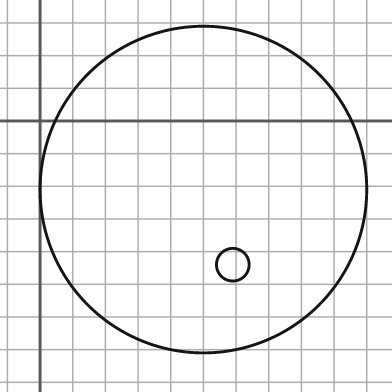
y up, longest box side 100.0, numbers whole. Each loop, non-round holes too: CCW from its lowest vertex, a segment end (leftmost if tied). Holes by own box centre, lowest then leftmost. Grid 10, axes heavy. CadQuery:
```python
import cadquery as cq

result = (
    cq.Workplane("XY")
    .moveTo(50.0, -21.0)
    .circle(50.0)
    .moveTo(59.0, -44.0)
    .circle(5.0)
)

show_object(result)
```